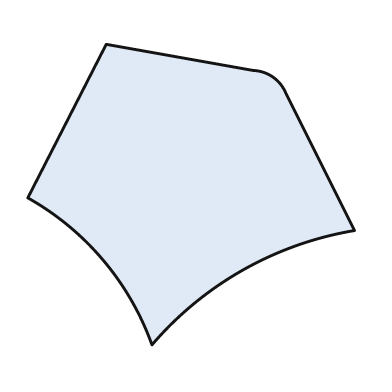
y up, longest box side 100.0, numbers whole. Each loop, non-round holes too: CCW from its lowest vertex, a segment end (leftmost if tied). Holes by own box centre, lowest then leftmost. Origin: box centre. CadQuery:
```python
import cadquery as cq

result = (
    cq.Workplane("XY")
    .moveTo(-12.0, -46.0)
    .threePointArc((16.0, -23.0), (50.0, -11.0))
    .lineTo(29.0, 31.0)
    .threePointArc((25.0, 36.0), (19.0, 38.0))
    .lineTo(-26.0, 46.0)
    .lineTo(-50.0, -1.0)
    .threePointArc((-27.0, -20.0), (-12.0, -46.0))
    .close()
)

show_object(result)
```